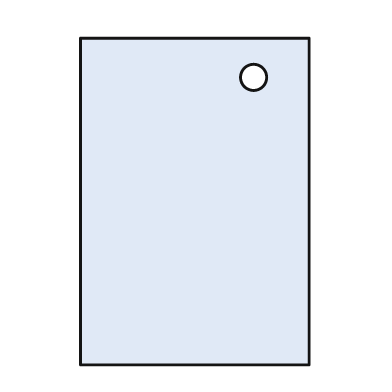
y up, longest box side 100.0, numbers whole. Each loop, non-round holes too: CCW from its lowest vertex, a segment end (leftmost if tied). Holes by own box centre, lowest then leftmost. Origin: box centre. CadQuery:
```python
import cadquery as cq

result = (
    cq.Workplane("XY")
    .moveTo(-35.0, -50.0)
    .lineTo(35.0, -50.0)
    .lineTo(35.0, 50.0)
    .lineTo(-35.0, 50.0)
    .close()
    .moveTo(18.0, 38.0)
    .circle(4.0)
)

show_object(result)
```